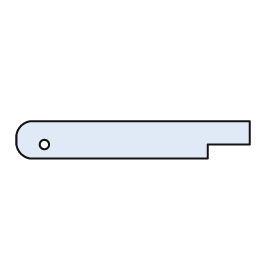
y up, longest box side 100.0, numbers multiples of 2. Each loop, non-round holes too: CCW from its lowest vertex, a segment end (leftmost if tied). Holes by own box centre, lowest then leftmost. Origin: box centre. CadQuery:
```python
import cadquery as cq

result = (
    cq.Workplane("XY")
    .moveTo(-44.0, -8.0)
    .lineTo(32.0, -8.0)
    .lineTo(32.0, -2.0)
    .lineTo(50.0, -2.0)
    .lineTo(50.0, 8.0)
    .lineTo(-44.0, 8.0)
    .threePointArc((-48.0, 6.0), (-50.0, 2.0))
    .lineTo(-50.0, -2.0)
    .threePointArc((-48.0, -6.0), (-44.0, -8.0))
    .close()
    .moveTo(-38.0, -2.0)
    .circle(2.0)
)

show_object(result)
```